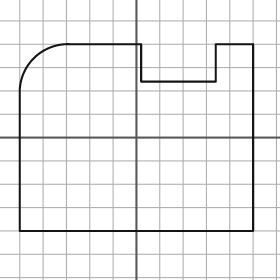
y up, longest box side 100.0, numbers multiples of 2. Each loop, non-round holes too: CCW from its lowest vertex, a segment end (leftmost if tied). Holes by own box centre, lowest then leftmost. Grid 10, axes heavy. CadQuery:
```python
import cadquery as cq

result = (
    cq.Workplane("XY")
    .moveTo(-50.0, -40.0)
    .lineTo(50.0, -40.0)
    .lineTo(50.0, 40.0)
    .lineTo(34.0, 40.0)
    .lineTo(34.0, 24.0)
    .lineTo(2.0, 24.0)
    .lineTo(2.0, 40.0)
    .lineTo(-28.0, 40.0)
    .threePointArc((-44.0, 34.0), (-50.0, 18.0))
    .close()
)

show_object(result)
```